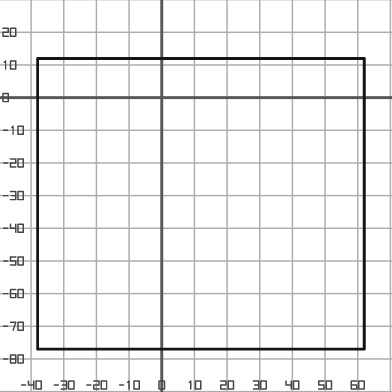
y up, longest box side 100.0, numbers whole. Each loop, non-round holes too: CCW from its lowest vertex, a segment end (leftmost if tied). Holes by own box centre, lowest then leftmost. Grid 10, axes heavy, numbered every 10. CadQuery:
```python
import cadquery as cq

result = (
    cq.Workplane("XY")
    .moveTo(-38.0, -77.0)
    .lineTo(62.0, -77.0)
    .lineTo(62.0, 12.0)
    .lineTo(-38.0, 12.0)
    .close()
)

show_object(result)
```